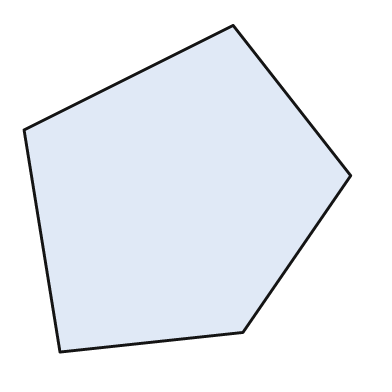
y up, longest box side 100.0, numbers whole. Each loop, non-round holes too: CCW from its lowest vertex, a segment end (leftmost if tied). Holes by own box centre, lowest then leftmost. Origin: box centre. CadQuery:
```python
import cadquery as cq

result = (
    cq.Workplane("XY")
    .moveTo(-39.0, -50.0)
    .lineTo(17.0, -44.0)
    .lineTo(50.0, 4.0)
    .lineTo(14.0, 50.0)
    .lineTo(-50.0, 18.0)
    .close()
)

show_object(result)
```